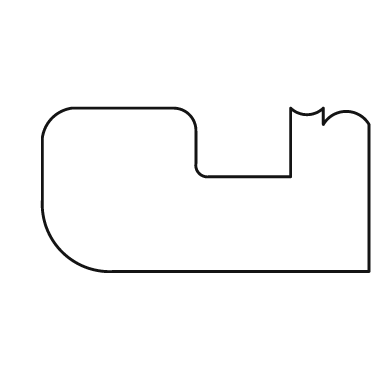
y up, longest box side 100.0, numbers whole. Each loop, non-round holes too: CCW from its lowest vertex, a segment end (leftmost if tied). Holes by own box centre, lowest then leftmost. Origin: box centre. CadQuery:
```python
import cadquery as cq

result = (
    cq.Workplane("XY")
    .moveTo(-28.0, -25.0)
    .lineTo(50.0, -25.0)
    .lineTo(50.0, 20.0)
    .threePointArc((43.0, 24.0), (36.0, 20.0))
    .lineTo(36.0, 25.0)
    .threePointArc((31.0, 23.0), (26.0, 25.0))
    .lineTo(26.0, 4.0)
    .lineTo(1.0, 4.0)
    .threePointArc((-2.0, 5.0), (-3.0, 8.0))
    .lineTo(-3.0, 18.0)
    .threePointArc((-5.0, 23.0), (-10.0, 25.0))
    .lineTo(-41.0, 25.0)
    .threePointArc((-47.0, 22.0), (-50.0, 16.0))
    .lineTo(-50.0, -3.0)
    .threePointArc((-44.0, -19.0), (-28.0, -25.0))
    .close()
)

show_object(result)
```